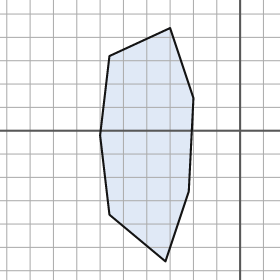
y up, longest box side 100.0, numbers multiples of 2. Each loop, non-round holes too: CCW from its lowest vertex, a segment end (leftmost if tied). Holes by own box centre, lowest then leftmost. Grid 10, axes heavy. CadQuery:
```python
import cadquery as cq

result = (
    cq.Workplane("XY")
    .moveTo(-32.0, -56.0)
    .lineTo(-22.0, -26.0)
    .lineTo(-20.0, 14.0)
    .lineTo(-30.0, 44.0)
    .lineTo(-56.0, 32.0)
    .lineTo(-60.0, -2.0)
    .lineTo(-56.0, -36.0)
    .close()
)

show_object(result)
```